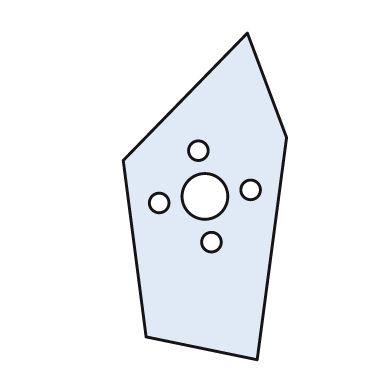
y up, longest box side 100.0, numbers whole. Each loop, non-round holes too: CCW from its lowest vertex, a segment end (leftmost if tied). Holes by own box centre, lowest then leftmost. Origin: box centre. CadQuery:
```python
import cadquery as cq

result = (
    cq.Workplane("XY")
    .moveTo(16.0, -50.0)
    .lineTo(25.0, 18.0)
    .lineTo(13.0, 50.0)
    .lineTo(-25.0, 11.0)
    .lineTo(-18.0, -43.0)
    .close()
    .moveTo(2.0, -14.0)
    .circle(3.0)
    .moveTo(-14.0, -2.0)
    .circle(3.0)
    .moveTo(0.0, 0.0)
    .circle(7.0)
    .moveTo(14.0, 2.0)
    .circle(3.0)
    .moveTo(-2.0, 14.0)
    .circle(3.0)
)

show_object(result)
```